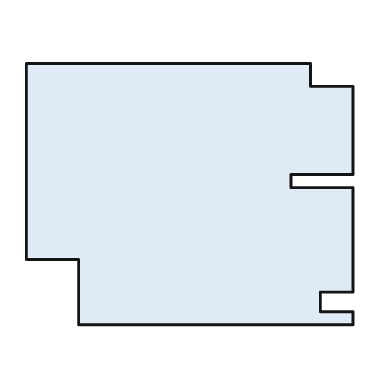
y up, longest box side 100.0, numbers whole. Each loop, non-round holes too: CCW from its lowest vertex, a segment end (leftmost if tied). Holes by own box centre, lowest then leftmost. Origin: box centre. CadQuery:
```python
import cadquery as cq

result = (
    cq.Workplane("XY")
    .moveTo(-34.0, -40.0)
    .lineTo(50.0, -40.0)
    .lineTo(50.0, -36.0)
    .lineTo(40.0, -36.0)
    .lineTo(40.0, -30.0)
    .lineTo(50.0, -30.0)
    .lineTo(50.0, 2.0)
    .lineTo(31.0, 2.0)
    .lineTo(31.0, 6.0)
    .lineTo(50.0, 6.0)
    .lineTo(50.0, 33.0)
    .lineTo(37.0, 33.0)
    .lineTo(37.0, 40.0)
    .lineTo(-50.0, 40.0)
    .lineTo(-50.0, -20.0)
    .lineTo(-34.0, -20.0)
    .close()
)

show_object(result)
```